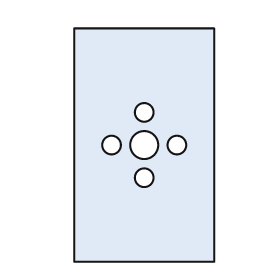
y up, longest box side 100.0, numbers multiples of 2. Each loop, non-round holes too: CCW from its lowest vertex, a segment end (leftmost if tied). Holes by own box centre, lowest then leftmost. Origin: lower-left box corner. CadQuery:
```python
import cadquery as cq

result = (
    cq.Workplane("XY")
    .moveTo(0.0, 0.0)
    .lineTo(60.0, 0.0)
    .lineTo(60.0, 100.0)
    .lineTo(0.0, 100.0)
    .close()
    .moveTo(30.0, 36.0)
    .circle(4.0)
    .moveTo(16.0, 50.0)
    .circle(4.0)
    .moveTo(30.0, 50.0)
    .circle(6.0)
    .moveTo(44.0, 50.0)
    .circle(4.0)
    .moveTo(30.0, 64.0)
    .circle(4.0)
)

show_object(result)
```